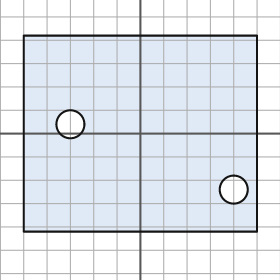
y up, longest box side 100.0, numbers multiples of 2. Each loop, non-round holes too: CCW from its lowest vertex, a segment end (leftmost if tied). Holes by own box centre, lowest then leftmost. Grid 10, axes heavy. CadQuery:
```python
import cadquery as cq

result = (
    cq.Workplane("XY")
    .moveTo(-50.0, -42.0)
    .lineTo(50.0, -42.0)
    .lineTo(50.0, 42.0)
    .lineTo(-50.0, 42.0)
    .close()
    .moveTo(40.0, -24.0)
    .circle(6.0)
    .moveTo(-30.0, 4.0)
    .circle(6.0)
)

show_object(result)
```